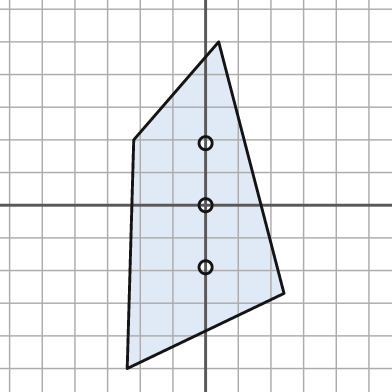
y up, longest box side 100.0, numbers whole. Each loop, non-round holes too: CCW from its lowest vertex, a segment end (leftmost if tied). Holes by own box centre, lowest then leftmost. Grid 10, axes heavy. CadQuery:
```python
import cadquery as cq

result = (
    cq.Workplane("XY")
    .moveTo(-24.0, -50.0)
    .lineTo(24.0, -27.0)
    .lineTo(4.0, 50.0)
    .lineTo(-22.0, 20.0)
    .close()
    .moveTo(0.0, -19.0)
    .circle(2.0)
    .moveTo(0.0, 0.0)
    .circle(2.0)
    .moveTo(0.0, 19.0)
    .circle(2.0)
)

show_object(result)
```